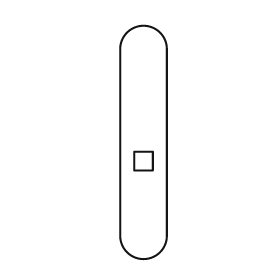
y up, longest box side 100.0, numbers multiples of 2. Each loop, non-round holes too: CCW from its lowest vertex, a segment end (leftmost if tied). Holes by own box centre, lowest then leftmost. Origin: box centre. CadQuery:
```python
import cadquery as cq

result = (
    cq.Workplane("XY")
    .moveTo(-10.0, -40.0)
    .threePointArc((0.0, -50.0), (10.0, -40.0))
    .lineTo(10.0, 40.0)
    .threePointArc((0.0, 50.0), (-10.0, 40.0))
    .close()
    .moveTo(-4.0, -12.0)
    .lineTo(4.0, -12.0)
    .lineTo(4.0, -4.0)
    .lineTo(-4.0, -4.0)
    .close()
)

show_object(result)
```